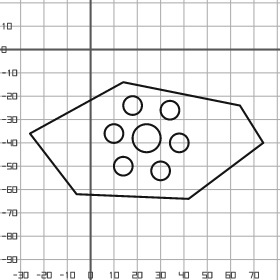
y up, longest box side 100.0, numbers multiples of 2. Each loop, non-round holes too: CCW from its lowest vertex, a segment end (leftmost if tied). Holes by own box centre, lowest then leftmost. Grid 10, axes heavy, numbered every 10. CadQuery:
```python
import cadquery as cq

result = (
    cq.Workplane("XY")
    .moveTo(42.0, -64.0)
    .lineTo(74.0, -40.0)
    .lineTo(64.0, -24.0)
    .lineTo(14.0, -14.0)
    .lineTo(-26.0, -36.0)
    .lineTo(-6.0, -62.0)
    .close()
    .moveTo(30.0, -52.0)
    .circle(4.0)
    .moveTo(14.0, -50.0)
    .circle(4.0)
    .moveTo(38.0, -40.0)
    .circle(4.0)
    .moveTo(24.0, -38.0)
    .circle(6.0)
    .moveTo(10.0, -36.0)
    .circle(4.0)
    .moveTo(34.0, -26.0)
    .circle(4.0)
    .moveTo(18.0, -24.0)
    .circle(4.0)
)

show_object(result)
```